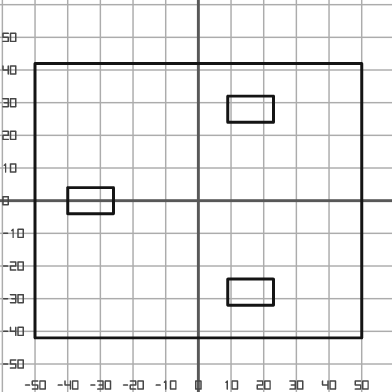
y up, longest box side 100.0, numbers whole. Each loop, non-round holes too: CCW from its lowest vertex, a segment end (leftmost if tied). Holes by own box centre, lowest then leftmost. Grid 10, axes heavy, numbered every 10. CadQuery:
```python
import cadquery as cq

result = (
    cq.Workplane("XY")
    .moveTo(-50.0, -42.0)
    .lineTo(50.0, -42.0)
    .lineTo(50.0, 42.0)
    .lineTo(-50.0, 42.0)
    .close()
    .moveTo(9.0, -32.0)
    .lineTo(23.0, -32.0)
    .lineTo(23.0, -24.0)
    .lineTo(9.0, -24.0)
    .close()
    .moveTo(-40.0, -4.0)
    .lineTo(-26.0, -4.0)
    .lineTo(-26.0, 4.0)
    .lineTo(-40.0, 4.0)
    .close()
    .moveTo(9.0, 24.0)
    .lineTo(23.0, 24.0)
    .lineTo(23.0, 32.0)
    .lineTo(9.0, 32.0)
    .close()
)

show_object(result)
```